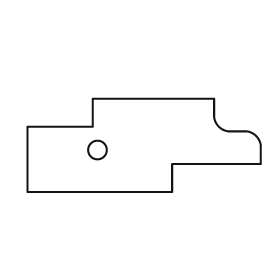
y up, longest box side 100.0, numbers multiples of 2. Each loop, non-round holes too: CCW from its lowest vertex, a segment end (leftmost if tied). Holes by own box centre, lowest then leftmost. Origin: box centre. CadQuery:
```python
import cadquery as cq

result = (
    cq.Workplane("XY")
    .moveTo(-50.0, -20.0)
    .lineTo(12.0, -20.0)
    .lineTo(12.0, -8.0)
    .lineTo(50.0, -8.0)
    .lineTo(50.0, 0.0)
    .threePointArc((48.0, 4.0), (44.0, 6.0))
    .lineTo(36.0, 6.0)
    .threePointArc((32.0, 8.0), (30.0, 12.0))
    .lineTo(30.0, 20.0)
    .lineTo(-22.0, 20.0)
    .lineTo(-22.0, 8.0)
    .lineTo(-50.0, 8.0)
    .close()
    .moveTo(-20.0, -2.0)
    .circle(4.0)
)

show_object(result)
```